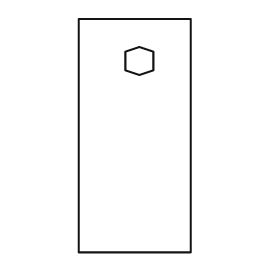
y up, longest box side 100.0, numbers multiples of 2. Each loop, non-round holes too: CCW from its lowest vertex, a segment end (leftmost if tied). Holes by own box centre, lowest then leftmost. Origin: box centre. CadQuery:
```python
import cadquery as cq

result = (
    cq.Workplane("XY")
    .moveTo(-24.0, -50.0)
    .lineTo(24.0, -50.0)
    .lineTo(24.0, 50.0)
    .lineTo(-24.0, 50.0)
    .close()
    .moveTo(2.0, 26.0)
    .lineTo(8.0, 28.0)
    .lineTo(8.0, 36.0)
    .lineTo(2.0, 38.0)
    .lineTo(-4.0, 36.0)
    .lineTo(-4.0, 28.0)
    .close()
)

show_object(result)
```